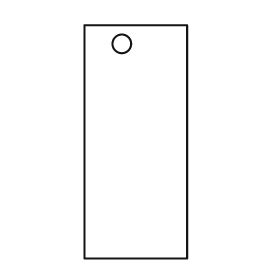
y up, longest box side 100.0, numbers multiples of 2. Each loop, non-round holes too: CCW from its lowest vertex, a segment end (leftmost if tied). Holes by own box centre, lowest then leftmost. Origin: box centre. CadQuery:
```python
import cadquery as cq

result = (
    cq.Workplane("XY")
    .moveTo(-22.0, -50.0)
    .lineTo(22.0, -50.0)
    .lineTo(22.0, 50.0)
    .lineTo(-22.0, 50.0)
    .close()
    .moveTo(-6.0, 42.0)
    .circle(4.0)
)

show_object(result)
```